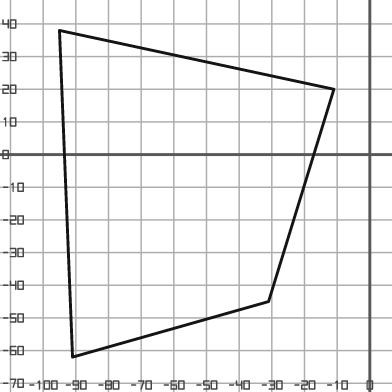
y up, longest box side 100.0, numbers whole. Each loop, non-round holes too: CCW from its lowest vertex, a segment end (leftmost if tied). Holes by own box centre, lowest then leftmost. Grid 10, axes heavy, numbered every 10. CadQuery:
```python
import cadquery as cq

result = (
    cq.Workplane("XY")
    .moveTo(-91.0, -62.0)
    .lineTo(-31.0, -45.0)
    .lineTo(-11.0, 20.0)
    .lineTo(-95.0, 38.0)
    .close()
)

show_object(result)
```